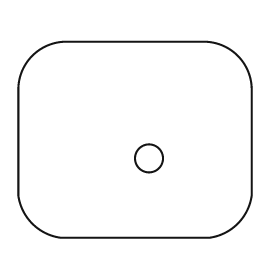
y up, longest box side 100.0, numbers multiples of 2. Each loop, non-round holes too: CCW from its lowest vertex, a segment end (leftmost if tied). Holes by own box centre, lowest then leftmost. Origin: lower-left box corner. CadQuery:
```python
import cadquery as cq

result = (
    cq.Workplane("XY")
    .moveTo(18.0, 0.0)
    .lineTo(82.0, 0.0)
    .threePointArc((94.0, 6.0), (100.0, 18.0))
    .lineTo(100.0, 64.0)
    .threePointArc((94.0, 78.0), (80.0, 84.0))
    .lineTo(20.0, 84.0)
    .threePointArc((6.0, 78.0), (0.0, 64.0))
    .lineTo(0.0, 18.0)
    .threePointArc((6.0, 6.0), (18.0, 0.0))
    .close()
    .moveTo(56.0, 34.0)
    .circle(6.0)
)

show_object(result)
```